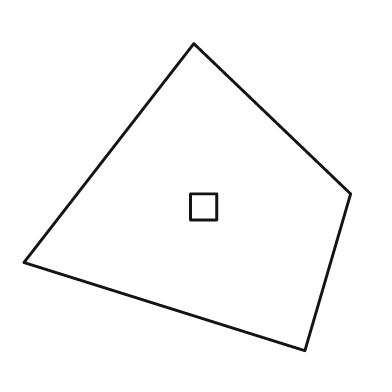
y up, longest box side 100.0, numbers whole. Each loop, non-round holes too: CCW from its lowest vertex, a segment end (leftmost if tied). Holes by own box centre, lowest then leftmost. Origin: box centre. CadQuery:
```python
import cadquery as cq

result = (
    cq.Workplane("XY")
    .moveTo(36.0, -47.0)
    .lineTo(50.0, 1.0)
    .lineTo(2.0, 47.0)
    .lineTo(-50.0, -20.0)
    .close()
    .moveTo(1.0, -7.0)
    .lineTo(9.0, -7.0)
    .lineTo(9.0, 1.0)
    .lineTo(1.0, 1.0)
    .close()
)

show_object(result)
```